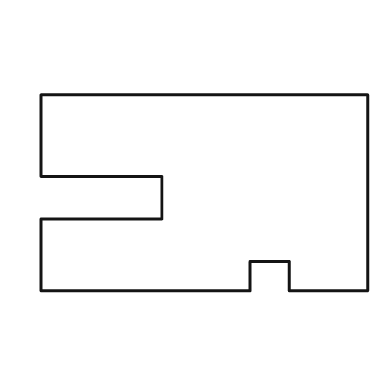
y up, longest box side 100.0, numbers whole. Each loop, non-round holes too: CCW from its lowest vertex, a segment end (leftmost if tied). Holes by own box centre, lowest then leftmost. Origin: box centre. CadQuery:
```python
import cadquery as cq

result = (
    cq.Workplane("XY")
    .moveTo(-50.0, -30.0)
    .lineTo(14.0, -30.0)
    .lineTo(14.0, -21.0)
    .lineTo(26.0, -21.0)
    .lineTo(26.0, -30.0)
    .lineTo(50.0, -30.0)
    .lineTo(50.0, 30.0)
    .lineTo(-50.0, 30.0)
    .lineTo(-50.0, 5.0)
    .lineTo(-13.0, 5.0)
    .lineTo(-13.0, -8.0)
    .lineTo(-50.0, -8.0)
    .close()
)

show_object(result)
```